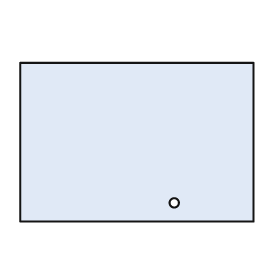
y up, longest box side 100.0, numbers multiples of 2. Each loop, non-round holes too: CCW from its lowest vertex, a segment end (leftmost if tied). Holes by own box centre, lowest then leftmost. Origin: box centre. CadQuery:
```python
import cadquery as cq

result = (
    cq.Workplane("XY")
    .moveTo(-50.0, -34.0)
    .lineTo(50.0, -34.0)
    .lineTo(50.0, 34.0)
    .lineTo(-50.0, 34.0)
    .close()
    .moveTo(16.0, -26.0)
    .circle(2.0)
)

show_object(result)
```